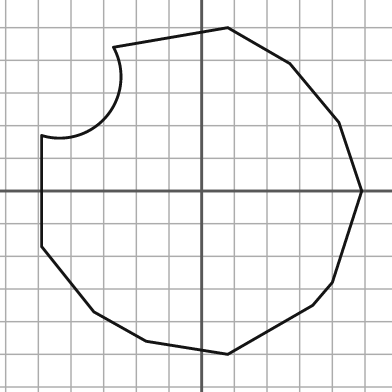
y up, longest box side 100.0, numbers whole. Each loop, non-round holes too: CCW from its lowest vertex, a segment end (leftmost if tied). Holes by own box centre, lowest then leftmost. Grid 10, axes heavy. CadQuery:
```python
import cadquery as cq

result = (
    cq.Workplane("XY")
    .moveTo(8.0, -50.0)
    .lineTo(34.0, -35.0)
    .lineTo(40.0, -28.0)
    .lineTo(49.0, 0.0)
    .lineTo(42.0, 21.0)
    .lineTo(27.0, 39.0)
    .lineTo(8.0, 50.0)
    .lineTo(-27.0, 44.0)
    .threePointArc((-29.0, 23.0), (-49.0, 17.0))
    .lineTo(-49.0, -17.0)
    .lineTo(-33.0, -37.0)
    .lineTo(-17.0, -46.0)
    .close()
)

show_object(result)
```